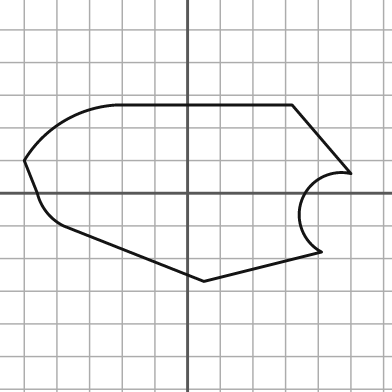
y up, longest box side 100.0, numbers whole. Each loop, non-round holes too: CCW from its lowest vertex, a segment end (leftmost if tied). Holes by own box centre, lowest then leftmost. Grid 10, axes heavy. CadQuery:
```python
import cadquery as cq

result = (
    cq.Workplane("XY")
    .moveTo(5.0, -27.0)
    .lineTo(41.0, -18.0)
    .threePointArc((35.0, -2.0), (50.0, 6.0))
    .lineTo(32.0, 27.0)
    .lineTo(-22.0, 27.0)
    .threePointArc((-38.0, 22.0), (-50.0, 10.0))
    .lineTo(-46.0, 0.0)
    .threePointArc((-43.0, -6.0), (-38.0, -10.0))
    .close()
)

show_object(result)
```